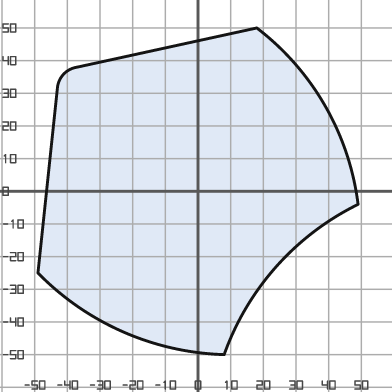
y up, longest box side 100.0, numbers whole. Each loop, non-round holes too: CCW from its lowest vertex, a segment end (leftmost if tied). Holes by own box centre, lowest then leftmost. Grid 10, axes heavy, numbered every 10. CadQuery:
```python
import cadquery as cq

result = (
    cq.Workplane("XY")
    .moveTo(8.0, -50.0)
    .threePointArc((24.0, -23.0), (49.0, -4.0))
    .threePointArc((39.0, 26.0), (18.0, 50.0))
    .lineTo(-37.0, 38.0)
    .threePointArc((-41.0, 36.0), (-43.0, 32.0))
    .lineTo(-49.0, -25.0)
    .threePointArc((-23.0, -43.0), (8.0, -50.0))
    .close()
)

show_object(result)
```